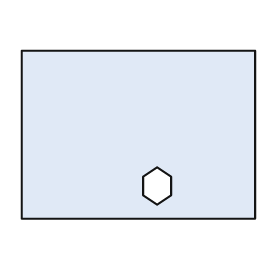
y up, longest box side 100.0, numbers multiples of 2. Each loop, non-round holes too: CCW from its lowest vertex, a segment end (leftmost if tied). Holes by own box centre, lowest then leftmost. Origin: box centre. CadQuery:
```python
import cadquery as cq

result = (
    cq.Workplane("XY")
    .moveTo(-50.0, -36.0)
    .lineTo(50.0, -36.0)
    .lineTo(50.0, 36.0)
    .lineTo(-50.0, 36.0)
    .close()
    .moveTo(8.0, -30.0)
    .lineTo(14.0, -26.0)
    .lineTo(14.0, -18.0)
    .lineTo(8.0, -14.0)
    .lineTo(2.0, -18.0)
    .lineTo(2.0, -26.0)
    .close()
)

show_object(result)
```